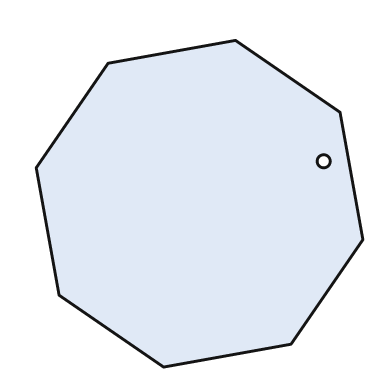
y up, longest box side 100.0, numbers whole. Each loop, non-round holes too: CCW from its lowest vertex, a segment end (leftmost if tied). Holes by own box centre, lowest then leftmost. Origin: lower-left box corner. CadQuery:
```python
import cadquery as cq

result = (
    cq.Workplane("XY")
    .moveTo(39.0, 0.0)
    .lineTo(78.0, 7.0)
    .lineTo(100.0, 39.0)
    .lineTo(93.0, 78.0)
    .lineTo(61.0, 100.0)
    .lineTo(22.0, 93.0)
    .lineTo(0.0, 61.0)
    .lineTo(7.0, 22.0)
    .close()
    .moveTo(88.0, 63.0)
    .circle(2.0)
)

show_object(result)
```